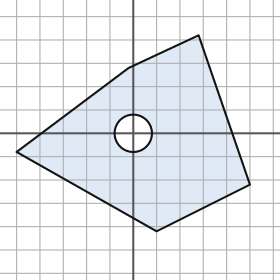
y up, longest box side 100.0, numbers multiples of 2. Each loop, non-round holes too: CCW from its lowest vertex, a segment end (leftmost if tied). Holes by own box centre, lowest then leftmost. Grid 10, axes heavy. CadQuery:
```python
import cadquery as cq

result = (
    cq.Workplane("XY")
    .moveTo(10.0, -42.0)
    .lineTo(50.0, -22.0)
    .lineTo(28.0, 42.0)
    .lineTo(-2.0, 28.0)
    .lineTo(-50.0, -8.0)
    .close()
    .moveTo(0.0, 0.0)
    .circle(8.0)
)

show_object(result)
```